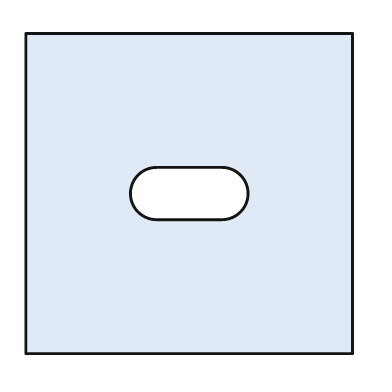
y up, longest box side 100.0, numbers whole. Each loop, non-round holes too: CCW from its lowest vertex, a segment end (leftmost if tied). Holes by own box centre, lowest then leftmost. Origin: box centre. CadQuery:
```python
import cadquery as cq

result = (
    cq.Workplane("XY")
    .moveTo(-50.0, -49.0)
    .lineTo(50.0, -49.0)
    .lineTo(50.0, 49.0)
    .lineTo(-50.0, 49.0)
    .close()
    .moveTo(-10.0, -8.0)
    .lineTo(10.0, -8.0)
    .threePointArc((18.0, 0.0), (10.0, 8.0))
    .lineTo(-10.0, 8.0)
    .threePointArc((-18.0, 0.0), (-10.0, -8.0))
    .close()
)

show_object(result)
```